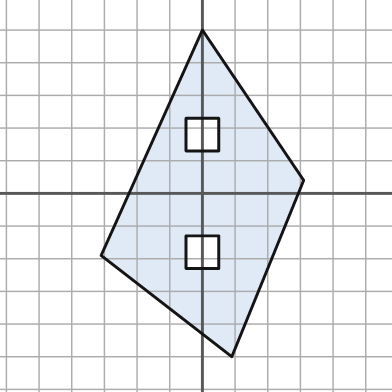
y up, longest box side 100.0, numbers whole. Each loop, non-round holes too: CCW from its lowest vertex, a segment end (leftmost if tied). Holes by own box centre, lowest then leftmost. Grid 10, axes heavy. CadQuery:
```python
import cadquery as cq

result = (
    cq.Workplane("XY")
    .moveTo(9.0, -50.0)
    .lineTo(31.0, 4.0)
    .lineTo(0.0, 50.0)
    .lineTo(-31.0, -19.0)
    .close()
    .moveTo(-5.0, -23.0)
    .lineTo(5.0, -23.0)
    .lineTo(5.0, -13.0)
    .lineTo(-5.0, -13.0)
    .close()
    .moveTo(-5.0, 13.0)
    .lineTo(5.0, 13.0)
    .lineTo(5.0, 23.0)
    .lineTo(-5.0, 23.0)
    .close()
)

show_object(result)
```